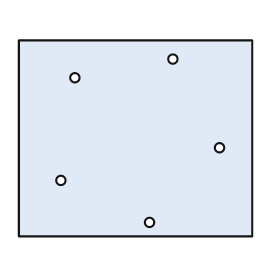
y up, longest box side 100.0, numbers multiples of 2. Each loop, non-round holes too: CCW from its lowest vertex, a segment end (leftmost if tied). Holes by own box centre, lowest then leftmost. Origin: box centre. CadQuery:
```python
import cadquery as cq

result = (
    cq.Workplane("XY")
    .moveTo(-50.0, -42.0)
    .lineTo(50.0, -42.0)
    .lineTo(50.0, 42.0)
    .lineTo(-50.0, 42.0)
    .close()
    .moveTo(6.0, -36.0)
    .circle(2.0)
    .moveTo(-32.0, -18.0)
    .circle(2.0)
    .moveTo(36.0, -4.0)
    .circle(2.0)
    .moveTo(-26.0, 26.0)
    .circle(2.0)
    .moveTo(16.0, 34.0)
    .circle(2.0)
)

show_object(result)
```